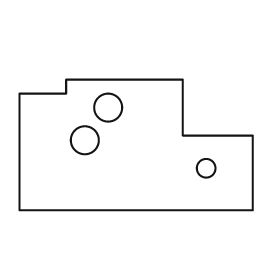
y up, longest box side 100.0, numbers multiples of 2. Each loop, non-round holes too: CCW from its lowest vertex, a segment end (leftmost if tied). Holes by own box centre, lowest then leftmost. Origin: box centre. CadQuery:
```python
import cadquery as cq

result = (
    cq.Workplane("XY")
    .moveTo(-50.0, -28.0)
    .lineTo(50.0, -28.0)
    .lineTo(50.0, 4.0)
    .lineTo(20.0, 4.0)
    .lineTo(20.0, 28.0)
    .lineTo(-30.0, 28.0)
    .lineTo(-30.0, 22.0)
    .lineTo(-50.0, 22.0)
    .close()
    .moveTo(30.0, -10.0)
    .circle(4.0)
    .moveTo(-22.0, 2.0)
    .circle(6.0)
    .moveTo(-12.0, 16.0)
    .circle(6.0)
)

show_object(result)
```